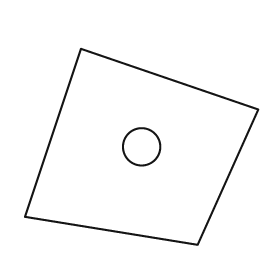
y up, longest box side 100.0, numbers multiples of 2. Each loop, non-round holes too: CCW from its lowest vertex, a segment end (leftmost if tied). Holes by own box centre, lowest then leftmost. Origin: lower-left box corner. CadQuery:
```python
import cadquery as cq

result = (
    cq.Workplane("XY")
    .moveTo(74.0, 0.0)
    .lineTo(100.0, 58.0)
    .lineTo(24.0, 84.0)
    .lineTo(0.0, 12.0)
    .close()
    .moveTo(50.0, 42.0)
    .circle(8.0)
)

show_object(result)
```